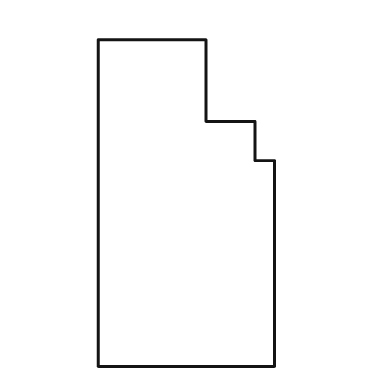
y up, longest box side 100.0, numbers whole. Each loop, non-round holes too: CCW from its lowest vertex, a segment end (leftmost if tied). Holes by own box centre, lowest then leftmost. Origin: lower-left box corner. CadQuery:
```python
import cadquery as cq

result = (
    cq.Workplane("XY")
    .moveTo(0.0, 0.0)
    .lineTo(54.0, 0.0)
    .lineTo(54.0, 63.0)
    .lineTo(48.0, 63.0)
    .lineTo(48.0, 75.0)
    .lineTo(33.0, 75.0)
    .lineTo(33.0, 100.0)
    .lineTo(0.0, 100.0)
    .close()
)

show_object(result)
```